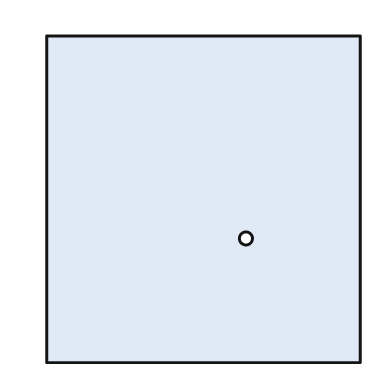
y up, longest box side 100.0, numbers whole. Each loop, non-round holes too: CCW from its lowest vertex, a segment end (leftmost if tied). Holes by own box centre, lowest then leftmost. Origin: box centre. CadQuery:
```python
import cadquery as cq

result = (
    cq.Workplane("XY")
    .moveTo(-48.0, -50.0)
    .lineTo(48.0, -50.0)
    .lineTo(48.0, 50.0)
    .lineTo(-48.0, 50.0)
    .close()
    .moveTo(13.0, -12.0)
    .circle(2.0)
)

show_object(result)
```